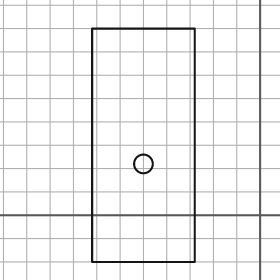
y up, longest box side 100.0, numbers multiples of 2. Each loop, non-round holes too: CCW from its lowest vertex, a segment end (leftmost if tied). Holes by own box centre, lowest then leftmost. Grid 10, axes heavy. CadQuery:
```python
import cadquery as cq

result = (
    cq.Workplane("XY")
    .moveTo(-72.0, -20.0)
    .lineTo(-28.0, -20.0)
    .lineTo(-28.0, 80.0)
    .lineTo(-72.0, 80.0)
    .close()
    .moveTo(-50.0, 22.0)
    .circle(4.0)
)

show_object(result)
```